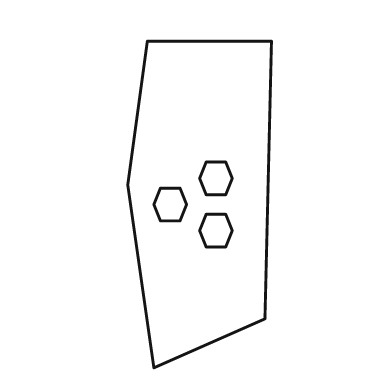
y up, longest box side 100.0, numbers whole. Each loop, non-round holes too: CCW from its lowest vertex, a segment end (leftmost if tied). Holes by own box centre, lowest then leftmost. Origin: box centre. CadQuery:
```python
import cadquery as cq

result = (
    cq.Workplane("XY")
    .moveTo(-14.0, -50.0)
    .lineTo(20.0, -35.0)
    .lineTo(22.0, 50.0)
    .lineTo(-16.0, 50.0)
    .lineTo(-22.0, 6.0)
    .close()
    .moveTo(2.0, -13.0)
    .lineTo(8.0, -13.0)
    .lineTo(10.0, -8.0)
    .lineTo(8.0, -3.0)
    .lineTo(2.0, -3.0)
    .lineTo(0.0, -8.0)
    .close()
    .moveTo(-12.0, -5.0)
    .lineTo(-6.0, -5.0)
    .lineTo(-4.0, 0.0)
    .lineTo(-6.0, 5.0)
    .lineTo(-12.0, 5.0)
    .lineTo(-14.0, 0.0)
    .close()
    .moveTo(2.0, 3.0)
    .lineTo(8.0, 3.0)
    .lineTo(10.0, 8.0)
    .lineTo(8.0, 13.0)
    .lineTo(2.0, 13.0)
    .lineTo(0.0, 8.0)
    .close()
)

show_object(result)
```